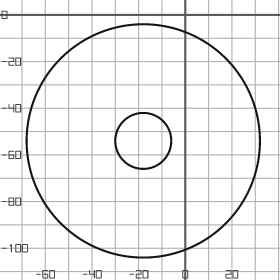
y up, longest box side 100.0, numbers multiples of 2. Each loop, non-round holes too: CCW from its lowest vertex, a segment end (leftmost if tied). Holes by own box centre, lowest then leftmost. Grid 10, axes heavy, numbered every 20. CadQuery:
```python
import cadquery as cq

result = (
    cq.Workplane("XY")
    .moveTo(-18.0, -54.0)
    .circle(50.0)
    .moveTo(-18.0, -54.0)
    .circle(12.0)
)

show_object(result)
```